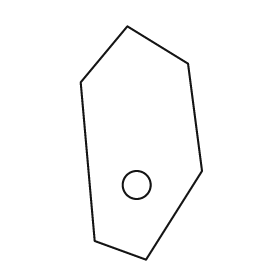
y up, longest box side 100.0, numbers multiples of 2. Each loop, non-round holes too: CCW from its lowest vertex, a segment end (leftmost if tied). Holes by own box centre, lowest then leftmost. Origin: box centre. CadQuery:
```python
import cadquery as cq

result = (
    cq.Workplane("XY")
    .moveTo(2.0, -50.0)
    .lineTo(26.0, -12.0)
    .lineTo(20.0, 34.0)
    .lineTo(-6.0, 50.0)
    .lineTo(-26.0, 26.0)
    .lineTo(-20.0, -42.0)
    .close()
    .moveTo(-2.0, -18.0)
    .circle(6.0)
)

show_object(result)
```